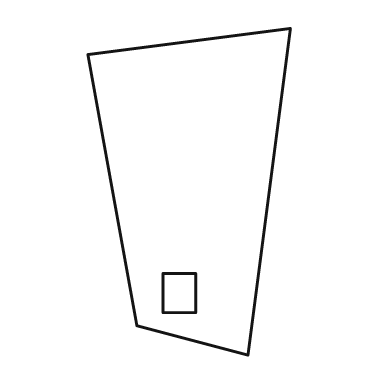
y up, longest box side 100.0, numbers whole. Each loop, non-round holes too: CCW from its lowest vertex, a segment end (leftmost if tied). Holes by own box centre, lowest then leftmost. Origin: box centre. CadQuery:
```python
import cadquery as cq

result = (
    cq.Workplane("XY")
    .moveTo(18.0, -50.0)
    .lineTo(31.0, 50.0)
    .lineTo(-31.0, 42.0)
    .lineTo(-16.0, -41.0)
    .close()
    .moveTo(-8.0, -37.0)
    .lineTo(2.0, -37.0)
    .lineTo(2.0, -25.0)
    .lineTo(-8.0, -25.0)
    .close()
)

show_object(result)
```